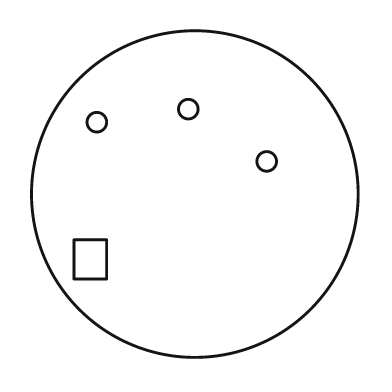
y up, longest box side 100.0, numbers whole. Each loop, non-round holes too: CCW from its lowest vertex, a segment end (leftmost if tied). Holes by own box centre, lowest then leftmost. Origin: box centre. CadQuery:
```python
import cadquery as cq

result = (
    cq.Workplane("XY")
    .moveTo(0.0, 0.0)
    .circle(50.0)
    .moveTo(-37.0, -26.0)
    .lineTo(-27.0, -26.0)
    .lineTo(-27.0, -14.0)
    .lineTo(-37.0, -14.0)
    .close()
    .moveTo(22.0, 10.0)
    .circle(3.0)
    .moveTo(-30.0, 22.0)
    .circle(3.0)
    .moveTo(-2.0, 26.0)
    .circle(3.0)
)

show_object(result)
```